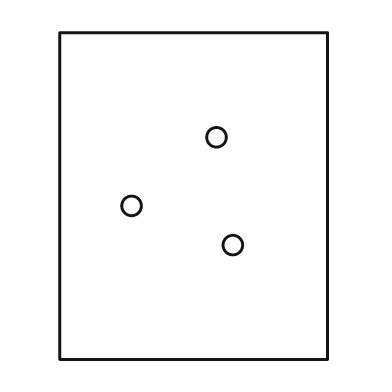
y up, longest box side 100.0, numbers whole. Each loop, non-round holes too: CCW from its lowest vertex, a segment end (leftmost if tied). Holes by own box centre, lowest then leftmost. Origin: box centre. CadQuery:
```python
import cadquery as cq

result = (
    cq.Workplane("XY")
    .moveTo(-41.0, -50.0)
    .lineTo(41.0, -50.0)
    .lineTo(41.0, 50.0)
    .lineTo(-41.0, 50.0)
    .close()
    .moveTo(12.0, -15.0)
    .circle(3.0)
    .moveTo(-19.0, -3.0)
    .circle(3.0)
    .moveTo(7.0, 18.0)
    .circle(3.0)
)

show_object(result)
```